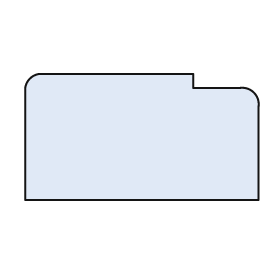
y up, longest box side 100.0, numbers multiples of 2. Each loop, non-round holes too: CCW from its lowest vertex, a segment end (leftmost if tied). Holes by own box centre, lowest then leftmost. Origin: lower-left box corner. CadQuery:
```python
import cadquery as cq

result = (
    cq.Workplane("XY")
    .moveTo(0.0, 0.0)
    .lineTo(100.0, 0.0)
    .lineTo(100.0, 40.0)
    .threePointArc((98.0, 46.0), (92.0, 48.0))
    .lineTo(72.0, 48.0)
    .lineTo(72.0, 54.0)
    .lineTo(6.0, 54.0)
    .threePointArc((2.0, 52.0), (0.0, 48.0))
    .close()
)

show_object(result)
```